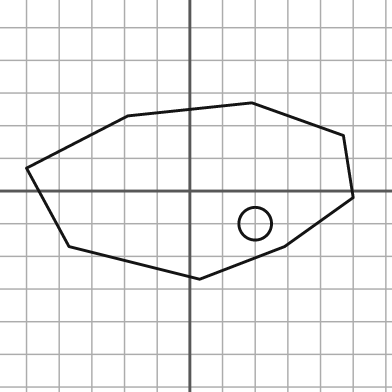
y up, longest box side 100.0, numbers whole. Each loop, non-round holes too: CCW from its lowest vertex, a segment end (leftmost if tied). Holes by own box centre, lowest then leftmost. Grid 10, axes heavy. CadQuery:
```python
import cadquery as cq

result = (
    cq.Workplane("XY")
    .moveTo(3.0, -27.0)
    .lineTo(29.0, -17.0)
    .lineTo(50.0, -2.0)
    .lineTo(47.0, 17.0)
    .lineTo(19.0, 27.0)
    .lineTo(-19.0, 23.0)
    .lineTo(-50.0, 7.0)
    .lineTo(-37.0, -17.0)
    .close()
    .moveTo(20.0, -10.0)
    .circle(5.0)
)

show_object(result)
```